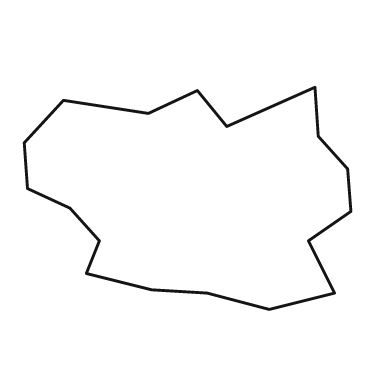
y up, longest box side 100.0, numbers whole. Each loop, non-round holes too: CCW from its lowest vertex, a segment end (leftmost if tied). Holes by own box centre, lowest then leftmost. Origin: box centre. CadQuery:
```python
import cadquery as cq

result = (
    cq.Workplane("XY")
    .moveTo(25.0, -34.0)
    .lineTo(45.0, -29.0)
    .lineTo(37.0, -13.0)
    .lineTo(50.0, -4.0)
    .lineTo(49.0, 9.0)
    .lineTo(40.0, 19.0)
    .lineTo(39.0, 34.0)
    .lineTo(12.0, 22.0)
    .lineTo(3.0, 33.0)
    .lineTo(-12.0, 26.0)
    .lineTo(-38.0, 30.0)
    .lineTo(-50.0, 17.0)
    .lineTo(-49.0, 3.0)
    .lineTo(-36.0, -3.0)
    .lineTo(-27.0, -13.0)
    .lineTo(-31.0, -23.0)
    .lineTo(-11.0, -28.0)
    .lineTo(6.0, -29.0)
    .close()
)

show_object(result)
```